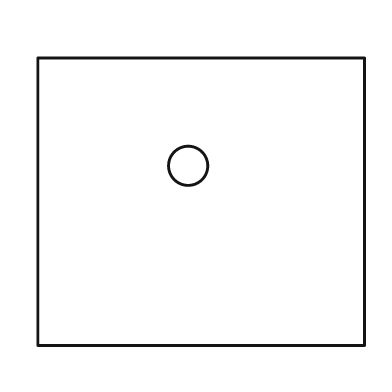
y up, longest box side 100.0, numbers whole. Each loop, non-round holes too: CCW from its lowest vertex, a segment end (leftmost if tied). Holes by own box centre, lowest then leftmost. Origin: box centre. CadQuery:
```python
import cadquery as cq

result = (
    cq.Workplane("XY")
    .moveTo(-50.0, -44.0)
    .lineTo(50.0, -44.0)
    .lineTo(50.0, 44.0)
    .lineTo(-50.0, 44.0)
    .close()
    .moveTo(-4.0, 11.0)
    .circle(6.0)
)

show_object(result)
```